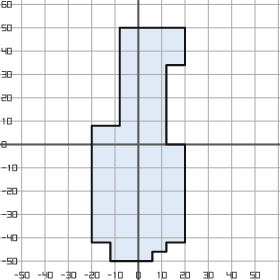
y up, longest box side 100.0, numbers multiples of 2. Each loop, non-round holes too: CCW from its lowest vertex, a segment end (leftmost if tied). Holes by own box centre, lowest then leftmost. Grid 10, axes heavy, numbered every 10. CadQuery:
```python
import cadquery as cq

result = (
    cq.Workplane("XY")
    .moveTo(-12.0, -50.0)
    .lineTo(6.0, -50.0)
    .lineTo(6.0, -46.0)
    .lineTo(12.0, -46.0)
    .lineTo(12.0, -42.0)
    .lineTo(20.0, -42.0)
    .lineTo(20.0, 0.0)
    .lineTo(12.0, 0.0)
    .lineTo(12.0, 34.0)
    .lineTo(20.0, 34.0)
    .lineTo(20.0, 50.0)
    .lineTo(-8.0, 50.0)
    .lineTo(-8.0, 8.0)
    .lineTo(-20.0, 8.0)
    .lineTo(-20.0, -42.0)
    .lineTo(-12.0, -42.0)
    .close()
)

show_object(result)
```